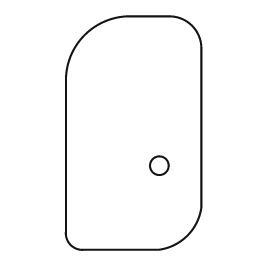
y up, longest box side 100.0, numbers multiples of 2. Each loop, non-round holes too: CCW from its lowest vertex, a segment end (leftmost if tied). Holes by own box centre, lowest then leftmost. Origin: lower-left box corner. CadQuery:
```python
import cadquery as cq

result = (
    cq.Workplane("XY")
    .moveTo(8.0, 0.0)
    .lineTo(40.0, 0.0)
    .threePointArc((52.0, 6.0), (58.0, 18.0))
    .lineTo(58.0, 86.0)
    .threePointArc((54.0, 96.0), (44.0, 100.0))
    .lineTo(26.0, 100.0)
    .threePointArc((8.0, 92.0), (0.0, 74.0))
    .lineTo(0.0, 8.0)
    .threePointArc((2.0, 2.0), (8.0, 0.0))
    .close()
    .moveTo(40.0, 36.0)
    .circle(4.0)
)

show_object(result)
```